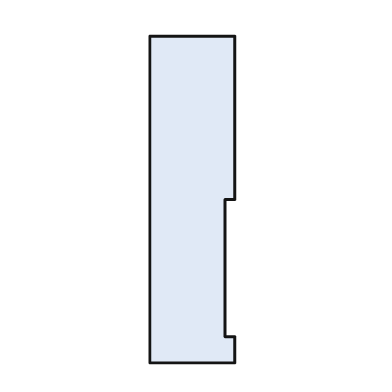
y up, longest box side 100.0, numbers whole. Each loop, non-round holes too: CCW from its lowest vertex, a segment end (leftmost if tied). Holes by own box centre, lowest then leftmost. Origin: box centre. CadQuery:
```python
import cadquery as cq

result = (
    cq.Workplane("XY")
    .moveTo(-13.0, -50.0)
    .lineTo(13.0, -50.0)
    .lineTo(13.0, -42.0)
    .lineTo(10.0, -42.0)
    .lineTo(10.0, 0.0)
    .lineTo(13.0, 0.0)
    .lineTo(13.0, 50.0)
    .lineTo(-13.0, 50.0)
    .close()
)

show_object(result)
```